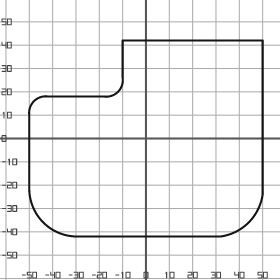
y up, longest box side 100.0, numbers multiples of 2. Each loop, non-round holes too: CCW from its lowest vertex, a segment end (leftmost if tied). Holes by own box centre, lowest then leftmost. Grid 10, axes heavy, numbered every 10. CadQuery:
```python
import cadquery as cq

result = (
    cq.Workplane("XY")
    .moveTo(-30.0, -42.0)
    .lineTo(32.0, -42.0)
    .threePointArc((44.0, -36.0), (50.0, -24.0))
    .lineTo(50.0, 42.0)
    .lineTo(-10.0, 42.0)
    .lineTo(-10.0, 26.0)
    .threePointArc((-12.0, 20.0), (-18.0, 18.0))
    .lineTo(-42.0, 18.0)
    .threePointArc((-48.0, 16.0), (-50.0, 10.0))
    .lineTo(-50.0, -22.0)
    .threePointArc((-44.0, -36.0), (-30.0, -42.0))
    .close()
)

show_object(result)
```